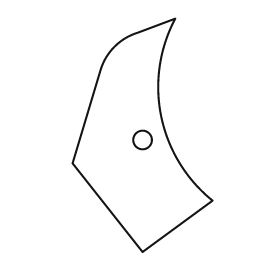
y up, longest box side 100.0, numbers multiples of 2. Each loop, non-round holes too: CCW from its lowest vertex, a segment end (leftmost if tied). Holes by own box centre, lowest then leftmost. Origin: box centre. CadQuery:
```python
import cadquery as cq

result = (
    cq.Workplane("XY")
    .moveTo(0.0, -50.0)
    .lineTo(30.0, -28.0)
    .threePointArc((8.0, 8.0), (14.0, 50.0))
    .lineTo(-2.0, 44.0)
    .threePointArc((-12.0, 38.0), (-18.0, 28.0))
    .lineTo(-30.0, -12.0)
    .close()
    .moveTo(0.0, -2.0)
    .circle(4.0)
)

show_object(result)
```